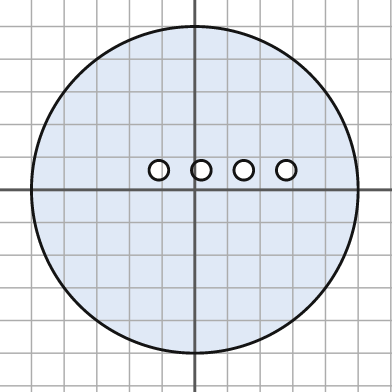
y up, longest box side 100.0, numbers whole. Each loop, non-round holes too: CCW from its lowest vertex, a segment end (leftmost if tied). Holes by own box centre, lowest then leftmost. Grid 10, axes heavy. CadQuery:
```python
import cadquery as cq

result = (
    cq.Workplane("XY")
    .moveTo(0.0, 0.0)
    .circle(50.0)
    .moveTo(-11.0, 6.0)
    .circle(3.0)
    .moveTo(2.0, 6.0)
    .circle(3.0)
    .moveTo(15.0, 6.0)
    .circle(3.0)
    .moveTo(28.0, 6.0)
    .circle(3.0)
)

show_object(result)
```